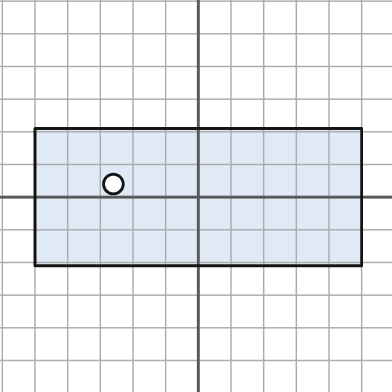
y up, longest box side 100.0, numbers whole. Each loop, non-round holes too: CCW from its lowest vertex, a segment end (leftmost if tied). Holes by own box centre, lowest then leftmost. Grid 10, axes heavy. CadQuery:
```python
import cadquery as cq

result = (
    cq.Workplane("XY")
    .moveTo(-50.0, -21.0)
    .lineTo(50.0, -21.0)
    .lineTo(50.0, 21.0)
    .lineTo(-50.0, 21.0)
    .close()
    .moveTo(-26.0, 4.0)
    .circle(3.0)
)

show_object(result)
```